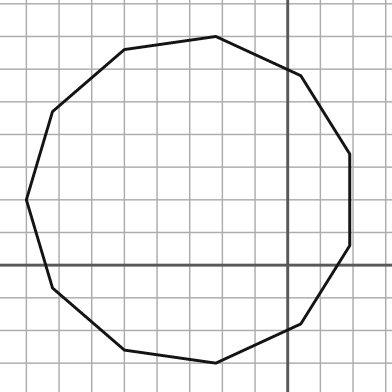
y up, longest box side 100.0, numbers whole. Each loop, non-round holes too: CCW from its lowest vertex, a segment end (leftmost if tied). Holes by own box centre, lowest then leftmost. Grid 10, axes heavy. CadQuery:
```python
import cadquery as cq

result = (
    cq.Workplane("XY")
    .moveTo(-22.0, -30.0)
    .lineTo(4.0, -18.0)
    .lineTo(19.0, 6.0)
    .lineTo(19.0, 34.0)
    .lineTo(4.0, 58.0)
    .lineTo(-22.0, 70.0)
    .lineTo(-50.0, 66.0)
    .lineTo(-72.0, 47.0)
    .lineTo(-80.0, 20.0)
    .lineTo(-72.0, -7.0)
    .lineTo(-50.0, -26.0)
    .close()
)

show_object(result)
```